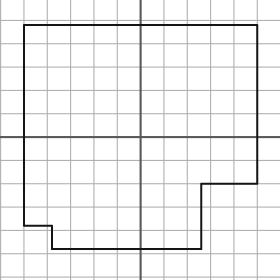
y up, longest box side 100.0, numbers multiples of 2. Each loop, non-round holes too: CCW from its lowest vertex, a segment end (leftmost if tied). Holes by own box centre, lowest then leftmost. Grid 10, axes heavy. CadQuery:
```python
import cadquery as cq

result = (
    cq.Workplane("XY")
    .moveTo(-38.0, -48.0)
    .lineTo(26.0, -48.0)
    .lineTo(26.0, -20.0)
    .lineTo(50.0, -20.0)
    .lineTo(50.0, 48.0)
    .lineTo(-50.0, 48.0)
    .lineTo(-50.0, -38.0)
    .lineTo(-38.0, -38.0)
    .close()
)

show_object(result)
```